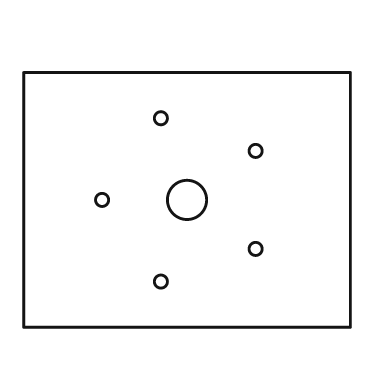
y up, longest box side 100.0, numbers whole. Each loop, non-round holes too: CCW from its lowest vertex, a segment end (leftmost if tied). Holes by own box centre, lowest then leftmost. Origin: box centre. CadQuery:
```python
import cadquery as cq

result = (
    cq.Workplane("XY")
    .moveTo(-50.0, -39.0)
    .lineTo(50.0, -39.0)
    .lineTo(50.0, 39.0)
    .lineTo(-50.0, 39.0)
    .close()
    .moveTo(-8.0, -25.0)
    .circle(2.0)
    .moveTo(21.0, -15.0)
    .circle(2.0)
    .moveTo(-26.0, 0.0)
    .circle(2.0)
    .moveTo(0.0, 0.0)
    .circle(6.0)
    .moveTo(21.0, 15.0)
    .circle(2.0)
    .moveTo(-8.0, 25.0)
    .circle(2.0)
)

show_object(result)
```